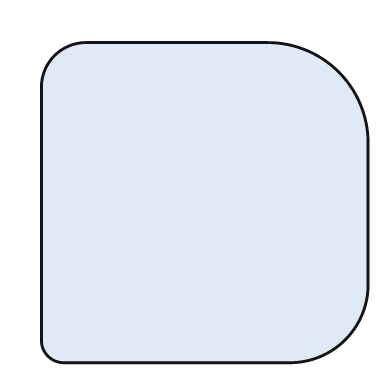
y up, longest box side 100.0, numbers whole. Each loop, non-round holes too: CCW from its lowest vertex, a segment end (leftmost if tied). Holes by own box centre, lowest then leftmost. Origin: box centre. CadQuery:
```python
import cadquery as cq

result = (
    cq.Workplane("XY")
    .moveTo(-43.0, -49.0)
    .lineTo(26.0, -49.0)
    .threePointArc((43.0, -42.0), (50.0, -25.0))
    .lineTo(50.0, 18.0)
    .threePointArc((41.0, 40.0), (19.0, 49.0))
    .lineTo(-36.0, 49.0)
    .threePointArc((-46.0, 45.0), (-50.0, 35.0))
    .lineTo(-50.0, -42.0)
    .threePointArc((-48.0, -47.0), (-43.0, -49.0))
    .close()
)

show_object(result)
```